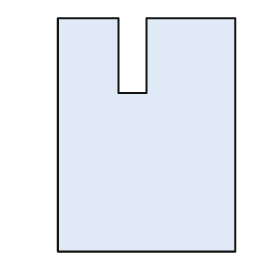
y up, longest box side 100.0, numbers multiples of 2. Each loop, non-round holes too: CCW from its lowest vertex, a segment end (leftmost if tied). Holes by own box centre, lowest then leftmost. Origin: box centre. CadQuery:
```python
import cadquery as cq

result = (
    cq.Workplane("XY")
    .moveTo(-38.0, -50.0)
    .lineTo(38.0, -50.0)
    .lineTo(38.0, 50.0)
    .lineTo(0.0, 50.0)
    .lineTo(0.0, 18.0)
    .lineTo(-12.0, 18.0)
    .lineTo(-12.0, 50.0)
    .lineTo(-38.0, 50.0)
    .close()
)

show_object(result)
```